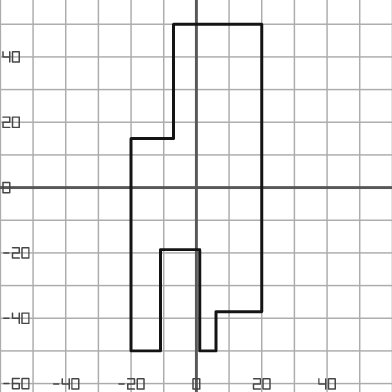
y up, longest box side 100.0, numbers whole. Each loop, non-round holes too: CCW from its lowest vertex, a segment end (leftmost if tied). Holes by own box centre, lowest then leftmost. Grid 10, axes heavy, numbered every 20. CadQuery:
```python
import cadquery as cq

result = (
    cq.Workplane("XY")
    .moveTo(-20.0, -50.0)
    .lineTo(-11.0, -50.0)
    .lineTo(-11.0, -19.0)
    .lineTo(1.0, -19.0)
    .lineTo(1.0, -50.0)
    .lineTo(6.0, -50.0)
    .lineTo(6.0, -38.0)
    .lineTo(20.0, -38.0)
    .lineTo(20.0, 50.0)
    .lineTo(-7.0, 50.0)
    .lineTo(-7.0, 15.0)
    .lineTo(-20.0, 15.0)
    .close()
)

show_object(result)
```